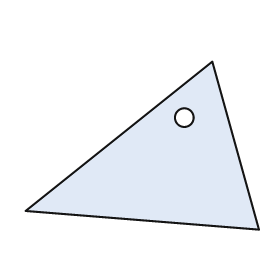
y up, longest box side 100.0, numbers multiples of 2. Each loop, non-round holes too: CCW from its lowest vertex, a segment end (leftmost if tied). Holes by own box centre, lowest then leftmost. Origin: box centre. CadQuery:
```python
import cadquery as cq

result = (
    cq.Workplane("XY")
    .moveTo(50.0, -36.0)
    .lineTo(30.0, 36.0)
    .lineTo(-50.0, -28.0)
    .close()
    .moveTo(18.0, 12.0)
    .circle(4.0)
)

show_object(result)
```